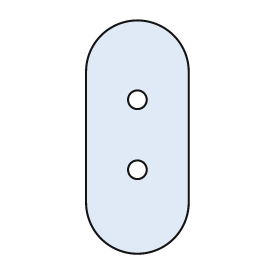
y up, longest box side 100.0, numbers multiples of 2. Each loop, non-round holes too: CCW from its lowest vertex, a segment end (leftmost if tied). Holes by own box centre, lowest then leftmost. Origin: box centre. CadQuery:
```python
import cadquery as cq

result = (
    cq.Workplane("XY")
    .moveTo(-22.0, -28.0)
    .threePointArc((0.0, -50.0), (22.0, -28.0))
    .lineTo(22.0, 28.0)
    .threePointArc((0.0, 50.0), (-22.0, 28.0))
    .close()
    .moveTo(0.0, -14.0)
    .circle(4.0)
    .moveTo(0.0, 16.0)
    .circle(4.0)
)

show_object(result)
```